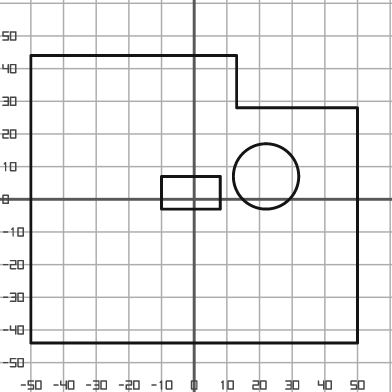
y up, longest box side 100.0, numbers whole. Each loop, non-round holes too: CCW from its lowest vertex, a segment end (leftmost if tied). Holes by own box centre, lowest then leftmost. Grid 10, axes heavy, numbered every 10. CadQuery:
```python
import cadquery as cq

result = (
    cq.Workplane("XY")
    .moveTo(-50.0, -44.0)
    .lineTo(50.0, -44.0)
    .lineTo(50.0, 28.0)
    .lineTo(13.0, 28.0)
    .lineTo(13.0, 44.0)
    .lineTo(-50.0, 44.0)
    .close()
    .moveTo(-10.0, -3.0)
    .lineTo(8.0, -3.0)
    .lineTo(8.0, 7.0)
    .lineTo(-10.0, 7.0)
    .close()
    .moveTo(22.0, 7.0)
    .circle(10.0)
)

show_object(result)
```